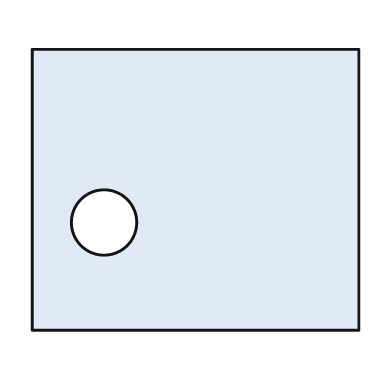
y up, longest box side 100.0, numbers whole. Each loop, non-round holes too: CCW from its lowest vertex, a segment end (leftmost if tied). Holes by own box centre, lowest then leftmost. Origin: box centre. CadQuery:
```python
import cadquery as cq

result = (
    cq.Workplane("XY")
    .moveTo(-50.0, -43.0)
    .lineTo(50.0, -43.0)
    .lineTo(50.0, 43.0)
    .lineTo(-50.0, 43.0)
    .close()
    .moveTo(-28.0, -10.0)
    .circle(10.0)
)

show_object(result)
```